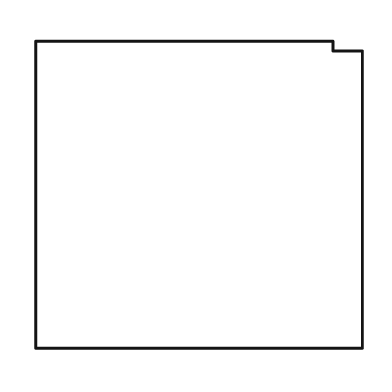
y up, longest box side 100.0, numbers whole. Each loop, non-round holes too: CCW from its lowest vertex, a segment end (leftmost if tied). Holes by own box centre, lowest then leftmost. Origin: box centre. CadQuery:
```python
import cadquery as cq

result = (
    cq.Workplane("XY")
    .moveTo(-50.0, -47.0)
    .lineTo(50.0, -47.0)
    .lineTo(50.0, 44.0)
    .lineTo(41.0, 44.0)
    .lineTo(41.0, 47.0)
    .lineTo(-50.0, 47.0)
    .close()
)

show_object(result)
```